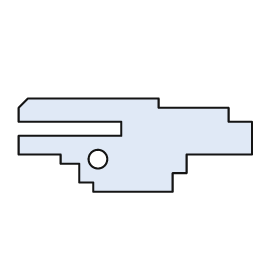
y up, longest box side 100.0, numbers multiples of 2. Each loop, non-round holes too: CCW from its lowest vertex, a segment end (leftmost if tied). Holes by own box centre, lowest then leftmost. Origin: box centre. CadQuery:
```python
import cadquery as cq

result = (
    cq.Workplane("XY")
    .moveTo(-18.0, -20.0)
    .lineTo(16.0, -20.0)
    .lineTo(16.0, -12.0)
    .lineTo(22.0, -12.0)
    .lineTo(22.0, -4.0)
    .lineTo(50.0, -4.0)
    .lineTo(50.0, 10.0)
    .lineTo(40.0, 10.0)
    .lineTo(40.0, 16.0)
    .lineTo(10.0, 16.0)
    .lineTo(10.0, 20.0)
    .lineTo(-46.0, 20.0)
    .lineTo(-50.0, 16.0)
    .lineTo(-50.0, 10.0)
    .lineTo(-6.0, 10.0)
    .lineTo(-6.0, 4.0)
    .lineTo(-50.0, 4.0)
    .lineTo(-50.0, -4.0)
    .lineTo(-32.0, -4.0)
    .lineTo(-32.0, -8.0)
    .lineTo(-24.0, -8.0)
    .lineTo(-24.0, -16.0)
    .lineTo(-18.0, -16.0)
    .close()
    .moveTo(-16.0, -6.0)
    .circle(4.0)
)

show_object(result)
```